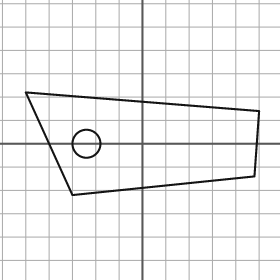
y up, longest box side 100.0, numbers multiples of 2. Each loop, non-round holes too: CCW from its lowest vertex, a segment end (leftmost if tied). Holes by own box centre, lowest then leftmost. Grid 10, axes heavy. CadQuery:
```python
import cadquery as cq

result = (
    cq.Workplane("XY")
    .moveTo(-30.0, -22.0)
    .lineTo(48.0, -14.0)
    .lineTo(50.0, 14.0)
    .lineTo(-50.0, 22.0)
    .close()
    .moveTo(-24.0, 0.0)
    .circle(6.0)
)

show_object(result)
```